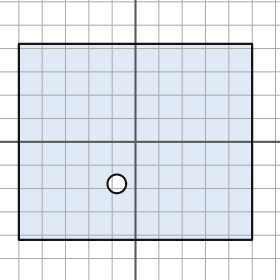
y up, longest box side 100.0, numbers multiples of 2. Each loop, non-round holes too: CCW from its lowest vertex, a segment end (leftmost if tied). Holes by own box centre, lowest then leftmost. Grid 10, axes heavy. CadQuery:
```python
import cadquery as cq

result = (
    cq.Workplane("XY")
    .moveTo(-50.0, -42.0)
    .lineTo(50.0, -42.0)
    .lineTo(50.0, 42.0)
    .lineTo(-50.0, 42.0)
    .close()
    .moveTo(-8.0, -18.0)
    .circle(4.0)
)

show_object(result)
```